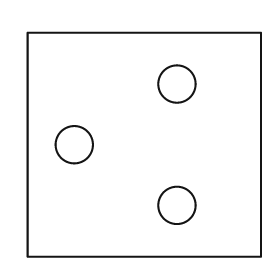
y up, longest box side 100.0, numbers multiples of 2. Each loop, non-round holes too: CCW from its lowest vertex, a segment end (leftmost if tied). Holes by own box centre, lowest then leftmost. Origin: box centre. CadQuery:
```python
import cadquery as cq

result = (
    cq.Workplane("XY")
    .moveTo(-50.0, -48.0)
    .lineTo(50.0, -48.0)
    .lineTo(50.0, 48.0)
    .lineTo(-50.0, 48.0)
    .close()
    .moveTo(14.0, -26.0)
    .circle(8.0)
    .moveTo(-30.0, 0.0)
    .circle(8.0)
    .moveTo(14.0, 26.0)
    .circle(8.0)
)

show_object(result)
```